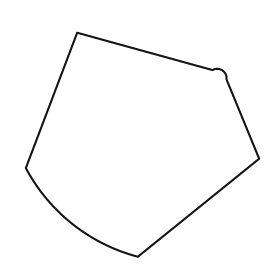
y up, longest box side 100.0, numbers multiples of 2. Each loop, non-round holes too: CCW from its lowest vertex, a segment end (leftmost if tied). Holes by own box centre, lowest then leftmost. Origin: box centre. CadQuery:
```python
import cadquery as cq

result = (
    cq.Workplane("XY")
    .moveTo(-2.0, -48.0)
    .lineTo(50.0, -6.0)
    .lineTo(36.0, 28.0)
    .threePointArc((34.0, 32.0), (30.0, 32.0))
    .lineTo(-28.0, 48.0)
    .lineTo(-50.0, -10.0)
    .threePointArc((-30.0, -34.0), (-2.0, -48.0))
    .close()
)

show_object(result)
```